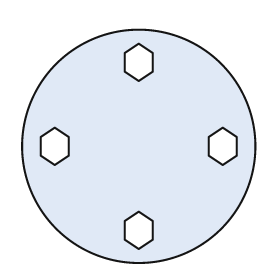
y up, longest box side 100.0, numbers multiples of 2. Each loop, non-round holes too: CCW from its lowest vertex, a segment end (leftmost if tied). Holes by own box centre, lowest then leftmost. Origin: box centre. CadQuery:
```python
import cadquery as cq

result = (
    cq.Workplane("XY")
    .moveTo(0.0, 0.0)
    .circle(50.0)
    .moveTo(0.0, -44.0)
    .lineTo(6.0, -40.0)
    .lineTo(6.0, -32.0)
    .lineTo(0.0, -28.0)
    .lineTo(-6.0, -32.0)
    .lineTo(-6.0, -40.0)
    .close()
    .moveTo(-36.0, -8.0)
    .lineTo(-30.0, -4.0)
    .lineTo(-30.0, 4.0)
    .lineTo(-36.0, 8.0)
    .lineTo(-42.0, 4.0)
    .lineTo(-42.0, -4.0)
    .close()
    .moveTo(36.0, -8.0)
    .lineTo(42.0, -4.0)
    .lineTo(42.0, 4.0)
    .lineTo(36.0, 8.0)
    .lineTo(30.0, 4.0)
    .lineTo(30.0, -4.0)
    .close()
    .moveTo(0.0, 28.0)
    .lineTo(6.0, 32.0)
    .lineTo(6.0, 40.0)
    .lineTo(0.0, 44.0)
    .lineTo(-6.0, 40.0)
    .lineTo(-6.0, 32.0)
    .close()
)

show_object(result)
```